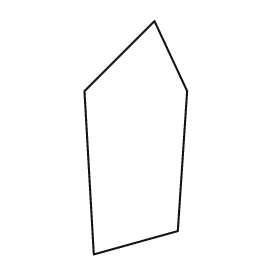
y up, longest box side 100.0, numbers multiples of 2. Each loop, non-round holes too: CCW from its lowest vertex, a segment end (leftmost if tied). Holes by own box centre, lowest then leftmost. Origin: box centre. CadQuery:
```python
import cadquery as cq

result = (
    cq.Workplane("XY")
    .moveTo(-18.0, -50.0)
    .lineTo(18.0, -40.0)
    .lineTo(22.0, 20.0)
    .lineTo(8.0, 50.0)
    .lineTo(-22.0, 20.0)
    .close()
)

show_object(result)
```